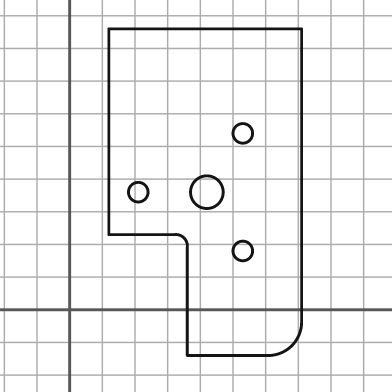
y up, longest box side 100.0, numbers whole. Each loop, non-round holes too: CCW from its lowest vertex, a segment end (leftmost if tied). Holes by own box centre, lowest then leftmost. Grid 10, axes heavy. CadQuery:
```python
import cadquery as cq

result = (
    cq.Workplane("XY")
    .moveTo(36.0, -14.0)
    .lineTo(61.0, -14.0)
    .threePointArc((68.0, -11.0), (71.0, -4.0))
    .lineTo(71.0, 86.0)
    .lineTo(12.0, 86.0)
    .lineTo(12.0, 23.0)
    .lineTo(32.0, 23.0)
    .threePointArc((35.0, 22.0), (36.0, 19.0))
    .close()
    .moveTo(53.0, 18.0)
    .circle(3.0)
    .moveTo(21.0, 36.0)
    .circle(3.0)
    .moveTo(42.0, 36.0)
    .circle(5.0)
    .moveTo(53.0, 54.0)
    .circle(3.0)
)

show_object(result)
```